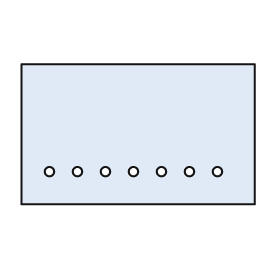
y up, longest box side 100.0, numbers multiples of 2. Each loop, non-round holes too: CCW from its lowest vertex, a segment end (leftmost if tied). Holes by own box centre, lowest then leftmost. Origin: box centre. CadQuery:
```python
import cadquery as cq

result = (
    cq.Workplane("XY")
    .moveTo(-50.0, -30.0)
    .lineTo(50.0, -30.0)
    .lineTo(50.0, 30.0)
    .lineTo(-50.0, 30.0)
    .close()
    .moveTo(-38.0, -16.0)
    .circle(2.0)
    .moveTo(-26.0, -16.0)
    .circle(2.0)
    .moveTo(-14.0, -16.0)
    .circle(2.0)
    .moveTo(-2.0, -16.0)
    .circle(2.0)
    .moveTo(10.0, -16.0)
    .circle(2.0)
    .moveTo(22.0, -16.0)
    .circle(2.0)
    .moveTo(34.0, -16.0)
    .circle(2.0)
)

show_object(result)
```